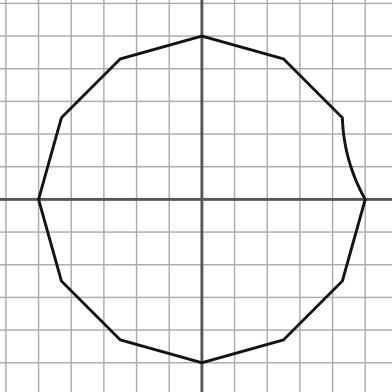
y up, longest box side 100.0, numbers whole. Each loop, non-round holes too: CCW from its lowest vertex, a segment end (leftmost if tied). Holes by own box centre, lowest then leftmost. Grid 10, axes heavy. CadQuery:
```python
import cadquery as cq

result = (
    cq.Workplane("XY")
    .moveTo(0.0, -50.0)
    .lineTo(25.0, -43.0)
    .lineTo(43.0, -25.0)
    .lineTo(50.0, 0.0)
    .threePointArc((45.0, 12.0), (43.0, 25.0))
    .lineTo(25.0, 43.0)
    .lineTo(0.0, 50.0)
    .lineTo(-25.0, 43.0)
    .lineTo(-43.0, 25.0)
    .lineTo(-50.0, 0.0)
    .lineTo(-43.0, -25.0)
    .lineTo(-25.0, -43.0)
    .close()
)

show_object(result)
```